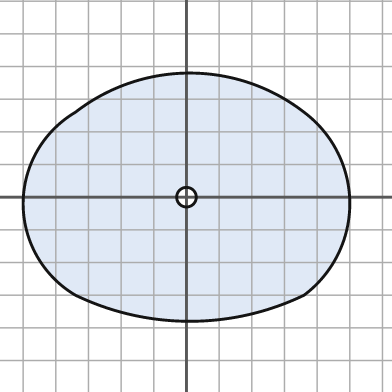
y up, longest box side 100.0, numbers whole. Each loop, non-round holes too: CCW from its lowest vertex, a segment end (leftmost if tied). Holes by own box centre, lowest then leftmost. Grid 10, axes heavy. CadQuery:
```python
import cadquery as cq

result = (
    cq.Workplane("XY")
    .moveTo(-34.0, -30.0)
    .threePointArc((1.0, -38.0), (36.0, -30.0))
    .threePointArc((50.0, -2.0), (36.0, 26.0))
    .threePointArc((1.0, 38.0), (-34.0, 26.0))
    .threePointArc((-50.0, -2.0), (-34.0, -30.0))
    .close()
    .moveTo(0.0, 0.0)
    .circle(3.0)
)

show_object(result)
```